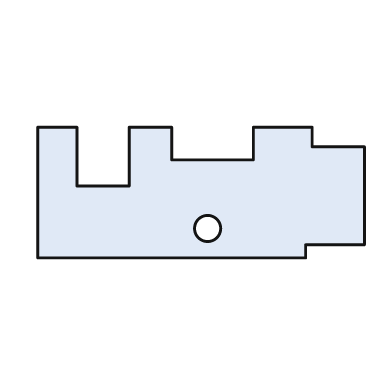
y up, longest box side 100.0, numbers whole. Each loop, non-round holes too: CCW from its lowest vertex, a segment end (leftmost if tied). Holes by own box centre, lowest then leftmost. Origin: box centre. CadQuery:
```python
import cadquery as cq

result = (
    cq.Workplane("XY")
    .moveTo(-50.0, -20.0)
    .lineTo(32.0, -20.0)
    .lineTo(32.0, -16.0)
    .lineTo(50.0, -16.0)
    .lineTo(50.0, 14.0)
    .lineTo(34.0, 14.0)
    .lineTo(34.0, 20.0)
    .lineTo(16.0, 20.0)
    .lineTo(16.0, 10.0)
    .lineTo(-9.0, 10.0)
    .lineTo(-9.0, 20.0)
    .lineTo(-22.0, 20.0)
    .lineTo(-22.0, 2.0)
    .lineTo(-38.0, 2.0)
    .lineTo(-38.0, 20.0)
    .lineTo(-50.0, 20.0)
    .close()
    .moveTo(2.0, -11.0)
    .circle(4.0)
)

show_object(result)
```